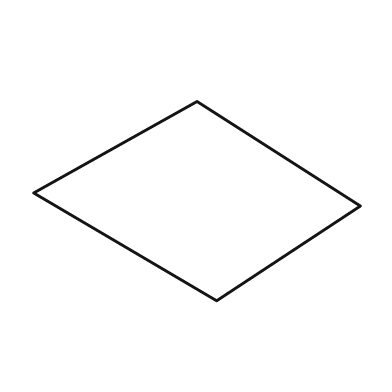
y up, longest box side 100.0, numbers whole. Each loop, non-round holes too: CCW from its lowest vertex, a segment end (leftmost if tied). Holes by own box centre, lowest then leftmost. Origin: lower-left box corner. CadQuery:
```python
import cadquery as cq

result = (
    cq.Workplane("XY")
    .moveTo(56.0, 0.0)
    .lineTo(100.0, 29.0)
    .lineTo(50.0, 61.0)
    .lineTo(0.0, 33.0)
    .close()
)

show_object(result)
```